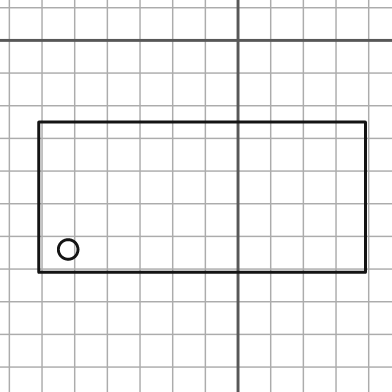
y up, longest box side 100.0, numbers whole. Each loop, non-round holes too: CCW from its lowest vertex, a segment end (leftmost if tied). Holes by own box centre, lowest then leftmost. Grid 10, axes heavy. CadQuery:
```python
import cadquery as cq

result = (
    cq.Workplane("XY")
    .moveTo(-61.0, -71.0)
    .lineTo(39.0, -71.0)
    .lineTo(39.0, -25.0)
    .lineTo(-61.0, -25.0)
    .close()
    .moveTo(-52.0, -64.0)
    .circle(3.0)
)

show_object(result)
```